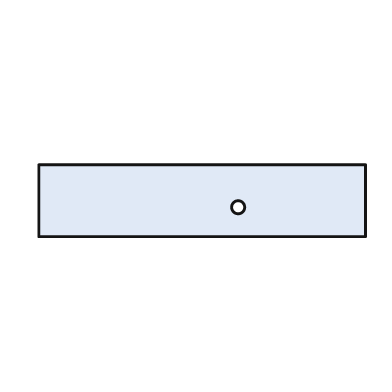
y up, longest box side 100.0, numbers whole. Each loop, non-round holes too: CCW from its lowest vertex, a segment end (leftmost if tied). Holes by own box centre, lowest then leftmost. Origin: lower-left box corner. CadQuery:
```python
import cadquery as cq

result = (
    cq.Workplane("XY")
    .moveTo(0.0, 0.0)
    .lineTo(100.0, 0.0)
    .lineTo(100.0, 22.0)
    .lineTo(0.0, 22.0)
    .close()
    .moveTo(61.0, 9.0)
    .circle(2.0)
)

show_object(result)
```